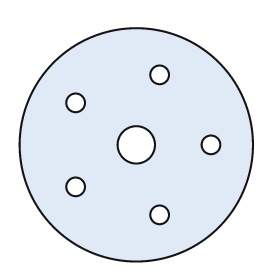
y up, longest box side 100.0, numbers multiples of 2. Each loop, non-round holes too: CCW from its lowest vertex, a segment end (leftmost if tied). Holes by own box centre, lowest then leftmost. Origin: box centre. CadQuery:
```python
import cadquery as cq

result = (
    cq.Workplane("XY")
    .moveTo(0.0, 0.0)
    .circle(50.0)
    .moveTo(10.0, -30.0)
    .circle(4.0)
    .moveTo(-26.0, -18.0)
    .circle(4.0)
    .moveTo(0.0, 0.0)
    .circle(8.0)
    .moveTo(32.0, 0.0)
    .circle(4.0)
    .moveTo(-26.0, 18.0)
    .circle(4.0)
    .moveTo(10.0, 30.0)
    .circle(4.0)
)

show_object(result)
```